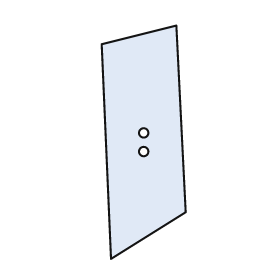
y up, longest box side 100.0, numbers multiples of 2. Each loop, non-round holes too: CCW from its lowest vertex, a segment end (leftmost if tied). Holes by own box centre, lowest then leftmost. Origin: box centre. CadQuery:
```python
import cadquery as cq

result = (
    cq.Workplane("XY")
    .moveTo(-14.0, -50.0)
    .lineTo(18.0, -30.0)
    .lineTo(14.0, 50.0)
    .lineTo(-18.0, 42.0)
    .close()
    .moveTo(0.0, -4.0)
    .circle(2.0)
    .moveTo(0.0, 4.0)
    .circle(2.0)
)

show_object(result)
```